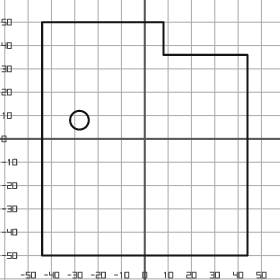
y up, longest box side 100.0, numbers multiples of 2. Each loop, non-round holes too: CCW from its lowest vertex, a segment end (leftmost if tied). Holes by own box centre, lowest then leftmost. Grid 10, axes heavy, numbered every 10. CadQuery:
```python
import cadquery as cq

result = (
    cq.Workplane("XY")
    .moveTo(-44.0, -50.0)
    .lineTo(44.0, -50.0)
    .lineTo(44.0, 36.0)
    .lineTo(8.0, 36.0)
    .lineTo(8.0, 50.0)
    .lineTo(-44.0, 50.0)
    .close()
    .moveTo(-28.0, 8.0)
    .circle(4.0)
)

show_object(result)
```